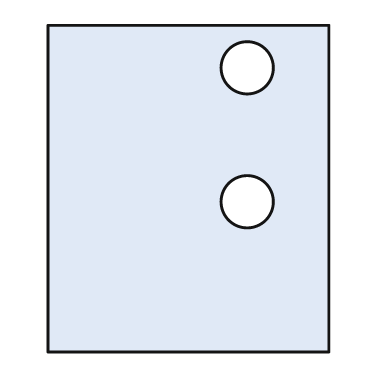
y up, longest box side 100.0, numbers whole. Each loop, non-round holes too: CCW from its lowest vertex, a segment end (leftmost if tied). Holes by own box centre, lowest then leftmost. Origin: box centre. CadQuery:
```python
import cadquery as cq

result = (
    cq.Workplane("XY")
    .moveTo(-43.0, -50.0)
    .lineTo(43.0, -50.0)
    .lineTo(43.0, 50.0)
    .lineTo(-43.0, 50.0)
    .close()
    .moveTo(18.0, -4.0)
    .circle(8.0)
    .moveTo(18.0, 37.0)
    .circle(8.0)
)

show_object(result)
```